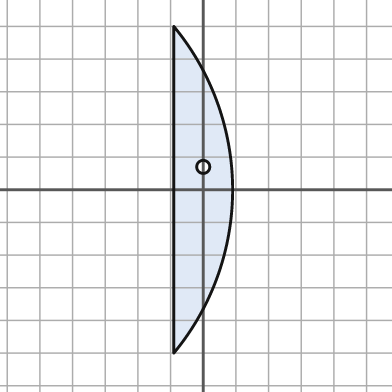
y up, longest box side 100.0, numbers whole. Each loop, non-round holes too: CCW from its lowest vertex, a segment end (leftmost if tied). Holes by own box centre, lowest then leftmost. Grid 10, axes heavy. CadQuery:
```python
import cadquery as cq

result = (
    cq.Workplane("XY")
    .moveTo(-9.0, -50.0)
    .threePointArc((9.0, 0.0), (-9.0, 50.0))
    .close()
    .moveTo(0.0, 7.0)
    .circle(2.0)
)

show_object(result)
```